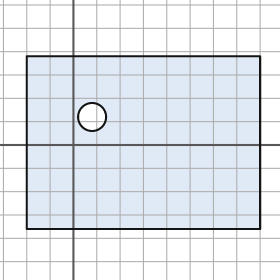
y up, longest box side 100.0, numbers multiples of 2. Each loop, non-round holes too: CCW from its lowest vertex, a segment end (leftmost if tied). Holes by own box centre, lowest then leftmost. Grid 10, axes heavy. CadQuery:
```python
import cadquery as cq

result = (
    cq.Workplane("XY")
    .moveTo(-20.0, -36.0)
    .lineTo(80.0, -36.0)
    .lineTo(80.0, 38.0)
    .lineTo(-20.0, 38.0)
    .close()
    .moveTo(8.0, 12.0)
    .circle(6.0)
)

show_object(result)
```